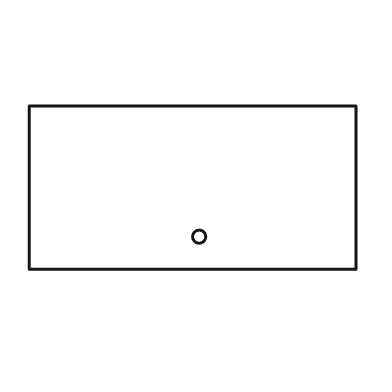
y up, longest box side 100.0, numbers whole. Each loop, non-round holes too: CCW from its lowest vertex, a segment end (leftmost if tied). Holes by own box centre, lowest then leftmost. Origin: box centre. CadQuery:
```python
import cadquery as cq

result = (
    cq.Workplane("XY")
    .moveTo(-50.0, -25.0)
    .lineTo(50.0, -25.0)
    .lineTo(50.0, 25.0)
    .lineTo(-50.0, 25.0)
    .close()
    .moveTo(2.0, -15.0)
    .circle(2.0)
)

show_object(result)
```